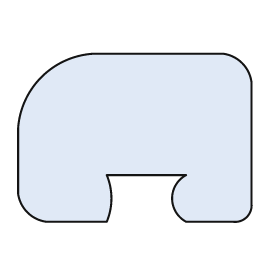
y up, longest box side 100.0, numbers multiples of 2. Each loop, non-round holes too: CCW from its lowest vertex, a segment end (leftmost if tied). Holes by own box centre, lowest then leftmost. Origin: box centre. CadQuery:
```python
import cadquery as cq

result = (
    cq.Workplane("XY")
    .moveTo(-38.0, -36.0)
    .lineTo(-12.0, -36.0)
    .threePointArc((-10.0, -26.0), (-12.0, -16.0))
    .lineTo(22.0, -16.0)
    .threePointArc((16.0, -26.0), (22.0, -36.0))
    .lineTo(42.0, -36.0)
    .threePointArc((48.0, -34.0), (50.0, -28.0))
    .lineTo(50.0, 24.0)
    .threePointArc((46.0, 32.0), (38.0, 36.0))
    .lineTo(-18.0, 36.0)
    .threePointArc((-40.0, 26.0), (-50.0, 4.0))
    .lineTo(-50.0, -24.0)
    .threePointArc((-46.0, -32.0), (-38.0, -36.0))
    .close()
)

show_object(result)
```